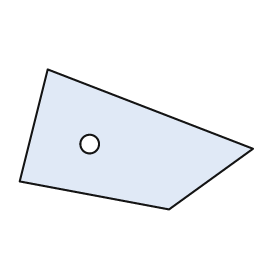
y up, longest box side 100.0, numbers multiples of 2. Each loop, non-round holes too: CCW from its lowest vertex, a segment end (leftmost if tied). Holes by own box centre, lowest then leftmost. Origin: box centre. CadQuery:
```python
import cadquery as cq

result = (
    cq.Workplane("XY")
    .moveTo(14.0, -30.0)
    .lineTo(50.0, -4.0)
    .lineTo(-38.0, 30.0)
    .lineTo(-50.0, -18.0)
    .close()
    .moveTo(-20.0, -2.0)
    .circle(4.0)
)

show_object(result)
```